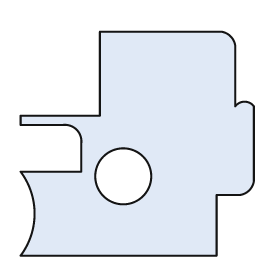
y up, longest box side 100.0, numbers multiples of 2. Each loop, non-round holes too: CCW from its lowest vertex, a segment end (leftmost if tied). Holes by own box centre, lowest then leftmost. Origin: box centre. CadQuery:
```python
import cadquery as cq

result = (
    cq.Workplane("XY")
    .moveTo(-50.0, -48.0)
    .lineTo(34.0, -48.0)
    .lineTo(34.0, -22.0)
    .lineTo(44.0, -22.0)
    .threePointArc((48.0, -20.0), (50.0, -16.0))
    .lineTo(50.0, 16.0)
    .threePointArc((46.0, 18.0), (42.0, 16.0))
    .lineTo(42.0, 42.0)
    .threePointArc((40.0, 46.0), (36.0, 48.0))
    .lineTo(-16.0, 48.0)
    .lineTo(-16.0, 12.0)
    .lineTo(-50.0, 12.0)
    .lineTo(-50.0, 8.0)
    .lineTo(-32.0, 8.0)
    .threePointArc((-26.0, 6.0), (-24.0, 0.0))
    .lineTo(-24.0, -12.0)
    .lineTo(-50.0, -12.0)
    .threePointArc((-44.0, -30.0), (-50.0, -48.0))
    .close()
    .moveTo(-6.0, -14.0)
    .circle(12.0)
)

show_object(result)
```